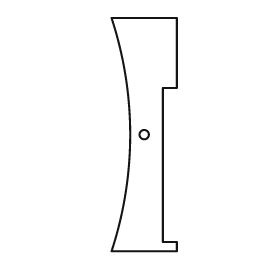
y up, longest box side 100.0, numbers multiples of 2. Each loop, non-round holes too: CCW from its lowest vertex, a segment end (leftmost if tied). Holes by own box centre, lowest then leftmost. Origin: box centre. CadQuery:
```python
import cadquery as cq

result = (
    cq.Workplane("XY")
    .moveTo(-14.0, -50.0)
    .lineTo(14.0, -50.0)
    .lineTo(14.0, -46.0)
    .lineTo(8.0, -46.0)
    .lineTo(8.0, 20.0)
    .lineTo(14.0, 20.0)
    .lineTo(14.0, 50.0)
    .lineTo(-14.0, 50.0)
    .threePointArc((-6.0, 0.0), (-14.0, -50.0))
    .close()
    .moveTo(0.0, 0.0)
    .circle(2.0)
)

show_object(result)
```